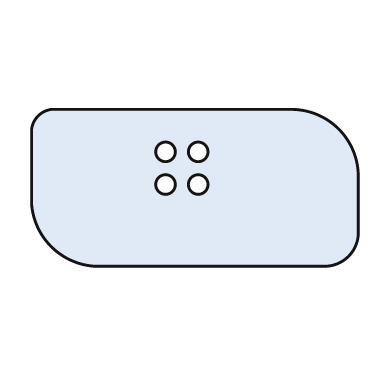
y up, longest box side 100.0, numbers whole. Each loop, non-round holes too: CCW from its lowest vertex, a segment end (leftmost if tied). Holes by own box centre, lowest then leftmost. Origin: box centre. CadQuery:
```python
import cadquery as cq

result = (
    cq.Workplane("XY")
    .moveTo(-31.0, -24.0)
    .lineTo(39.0, -24.0)
    .threePointArc((47.0, -21.0), (50.0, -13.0))
    .lineTo(50.0, 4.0)
    .threePointArc((44.0, 18.0), (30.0, 24.0))
    .lineTo(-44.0, 24.0)
    .threePointArc((-48.0, 22.0), (-50.0, 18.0))
    .lineTo(-50.0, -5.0)
    .threePointArc((-44.0, -18.0), (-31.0, -24.0))
    .close()
    .moveTo(-9.0, 1.0)
    .circle(3.0)
    .moveTo(1.0, 1.0)
    .circle(3.0)
    .moveTo(-9.0, 11.0)
    .circle(3.0)
    .moveTo(1.0, 11.0)
    .circle(3.0)
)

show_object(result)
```